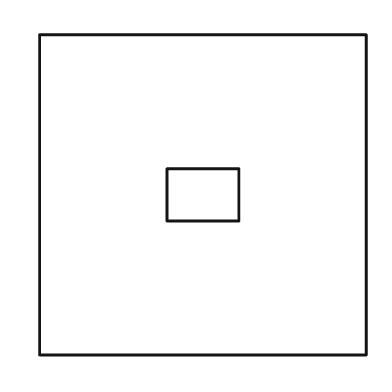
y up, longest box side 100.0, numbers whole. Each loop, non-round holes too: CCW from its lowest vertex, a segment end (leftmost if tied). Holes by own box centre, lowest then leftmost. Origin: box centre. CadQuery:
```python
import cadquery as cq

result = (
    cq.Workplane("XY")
    .moveTo(-50.0, -49.0)
    .lineTo(50.0, -49.0)
    .lineTo(50.0, 49.0)
    .lineTo(-50.0, 49.0)
    .close()
    .moveTo(-11.0, -8.0)
    .lineTo(11.0, -8.0)
    .lineTo(11.0, 8.0)
    .lineTo(-11.0, 8.0)
    .close()
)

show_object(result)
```